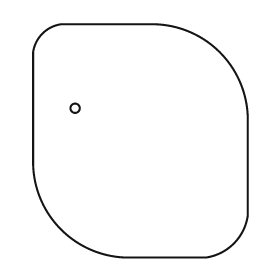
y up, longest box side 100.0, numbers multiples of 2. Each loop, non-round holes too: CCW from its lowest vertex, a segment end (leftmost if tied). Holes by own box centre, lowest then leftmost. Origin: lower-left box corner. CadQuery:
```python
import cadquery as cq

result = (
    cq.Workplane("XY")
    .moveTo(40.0, 0.0)
    .lineTo(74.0, 0.0)
    .threePointArc((86.0, 6.0), (92.0, 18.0))
    .lineTo(92.0, 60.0)
    .threePointArc((80.0, 88.0), (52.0, 100.0))
    .lineTo(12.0, 100.0)
    .threePointArc((4.0, 96.0), (0.0, 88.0))
    .lineTo(0.0, 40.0)
    .threePointArc((12.0, 12.0), (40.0, 0.0))
    .close()
    .moveTo(18.0, 64.0)
    .circle(2.0)
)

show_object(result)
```